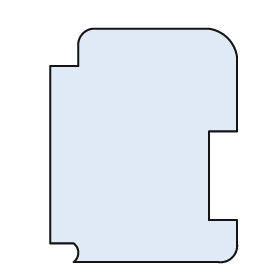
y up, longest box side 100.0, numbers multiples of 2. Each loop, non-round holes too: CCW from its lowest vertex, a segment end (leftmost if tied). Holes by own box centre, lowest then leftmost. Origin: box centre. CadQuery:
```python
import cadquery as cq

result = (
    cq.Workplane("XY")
    .moveTo(-30.0, -50.0)
    .lineTo(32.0, -50.0)
    .threePointArc((38.0, -48.0), (40.0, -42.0))
    .lineTo(40.0, -32.0)
    .lineTo(28.0, -32.0)
    .lineTo(28.0, 6.0)
    .lineTo(40.0, 6.0)
    .lineTo(40.0, 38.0)
    .threePointArc((36.0, 46.0), (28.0, 50.0))
    .lineTo(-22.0, 50.0)
    .threePointArc((-26.0, 48.0), (-28.0, 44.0))
    .lineTo(-28.0, 34.0)
    .lineTo(-40.0, 34.0)
    .lineTo(-40.0, -42.0)
    .lineTo(-30.0, -42.0)
    .threePointArc((-28.0, -46.0), (-30.0, -50.0))
    .close()
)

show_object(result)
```